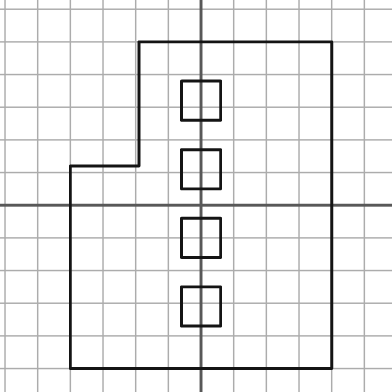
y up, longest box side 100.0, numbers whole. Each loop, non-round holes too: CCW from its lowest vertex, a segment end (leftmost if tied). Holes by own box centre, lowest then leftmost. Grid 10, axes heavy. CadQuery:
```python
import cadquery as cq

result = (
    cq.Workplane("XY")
    .moveTo(-40.0, -50.0)
    .lineTo(40.0, -50.0)
    .lineTo(40.0, 50.0)
    .lineTo(-19.0, 50.0)
    .lineTo(-19.0, 12.0)
    .lineTo(-40.0, 12.0)
    .close()
    .moveTo(-6.0, -37.0)
    .lineTo(6.0, -37.0)
    .lineTo(6.0, -25.0)
    .lineTo(-6.0, -25.0)
    .close()
    .moveTo(-6.0, -16.0)
    .lineTo(6.0, -16.0)
    .lineTo(6.0, -4.0)
    .lineTo(-6.0, -4.0)
    .close()
    .moveTo(-6.0, 5.0)
    .lineTo(6.0, 5.0)
    .lineTo(6.0, 17.0)
    .lineTo(-6.0, 17.0)
    .close()
    .moveTo(-6.0, 26.0)
    .lineTo(6.0, 26.0)
    .lineTo(6.0, 38.0)
    .lineTo(-6.0, 38.0)
    .close()
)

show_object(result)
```